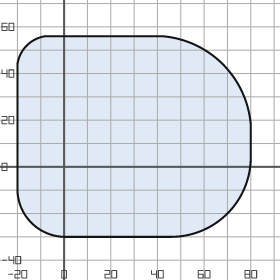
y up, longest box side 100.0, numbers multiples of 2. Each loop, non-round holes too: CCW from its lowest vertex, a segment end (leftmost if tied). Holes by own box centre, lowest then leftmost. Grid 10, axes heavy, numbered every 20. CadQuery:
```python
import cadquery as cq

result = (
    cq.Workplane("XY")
    .moveTo(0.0, -30.0)
    .lineTo(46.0, -30.0)
    .threePointArc((70.0, -20.0), (80.0, 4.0))
    .lineTo(80.0, 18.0)
    .threePointArc((68.0, 44.0), (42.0, 56.0))
    .lineTo(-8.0, 56.0)
    .threePointArc((-16.0, 52.0), (-20.0, 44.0))
    .lineTo(-20.0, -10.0)
    .threePointArc((-14.0, -24.0), (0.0, -30.0))
    .close()
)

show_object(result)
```